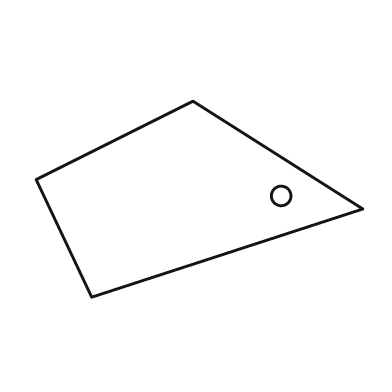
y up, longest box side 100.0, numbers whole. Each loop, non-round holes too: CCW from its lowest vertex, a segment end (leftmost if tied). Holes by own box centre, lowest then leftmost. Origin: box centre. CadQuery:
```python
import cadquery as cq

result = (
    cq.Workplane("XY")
    .moveTo(-33.0, -30.0)
    .lineTo(50.0, -3.0)
    .lineTo(-2.0, 30.0)
    .lineTo(-50.0, 6.0)
    .close()
    .moveTo(25.0, 1.0)
    .circle(3.0)
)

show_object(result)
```